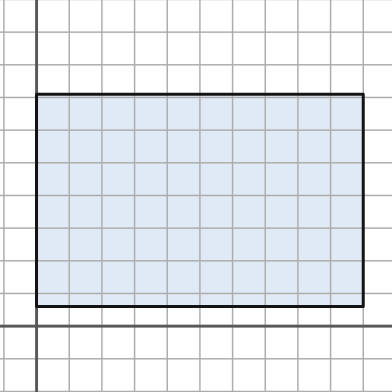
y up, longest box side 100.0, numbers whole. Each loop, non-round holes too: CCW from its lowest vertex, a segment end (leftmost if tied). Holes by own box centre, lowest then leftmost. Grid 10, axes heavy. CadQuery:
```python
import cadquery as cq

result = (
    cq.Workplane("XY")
    .moveTo(0.0, 6.0)
    .lineTo(100.0, 6.0)
    .lineTo(100.0, 71.0)
    .lineTo(0.0, 71.0)
    .close()
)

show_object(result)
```